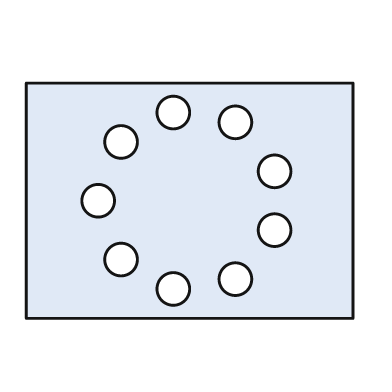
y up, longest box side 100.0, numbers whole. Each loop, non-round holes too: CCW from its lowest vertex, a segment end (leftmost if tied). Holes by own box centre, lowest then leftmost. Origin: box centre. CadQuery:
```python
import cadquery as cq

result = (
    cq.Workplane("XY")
    .moveTo(-50.0, -36.0)
    .lineTo(50.0, -36.0)
    .lineTo(50.0, 36.0)
    .lineTo(-50.0, 36.0)
    .close()
    .moveTo(-5.0, -27.0)
    .circle(5.0)
    .moveTo(14.0, -24.0)
    .circle(5.0)
    .moveTo(-21.0, -18.0)
    .circle(5.0)
    .moveTo(26.0, -9.0)
    .circle(5.0)
    .moveTo(-28.0, 0.0)
    .circle(5.0)
    .moveTo(26.0, 9.0)
    .circle(5.0)
    .moveTo(-21.0, 18.0)
    .circle(5.0)
    .moveTo(14.0, 24.0)
    .circle(5.0)
    .moveTo(-5.0, 27.0)
    .circle(5.0)
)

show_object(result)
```